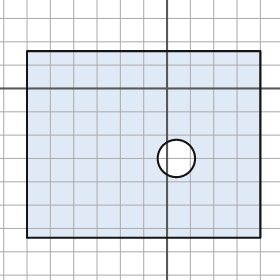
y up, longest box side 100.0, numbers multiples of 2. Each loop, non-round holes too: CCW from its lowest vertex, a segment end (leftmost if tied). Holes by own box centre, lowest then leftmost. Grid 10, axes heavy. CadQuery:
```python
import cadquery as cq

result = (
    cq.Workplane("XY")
    .moveTo(-60.0, -64.0)
    .lineTo(40.0, -64.0)
    .lineTo(40.0, 16.0)
    .lineTo(-60.0, 16.0)
    .close()
    .moveTo(4.0, -30.0)
    .circle(8.0)
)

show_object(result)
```